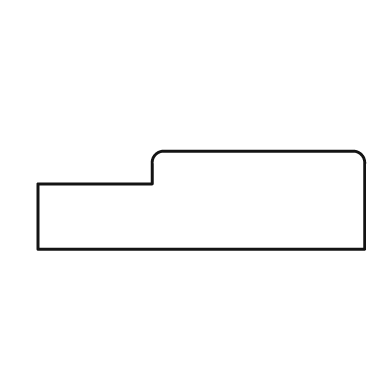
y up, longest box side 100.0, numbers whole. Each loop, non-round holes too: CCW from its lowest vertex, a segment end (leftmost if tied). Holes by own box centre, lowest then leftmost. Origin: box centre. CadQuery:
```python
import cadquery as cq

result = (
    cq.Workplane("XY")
    .moveTo(-50.0, -15.0)
    .lineTo(50.0, -15.0)
    .lineTo(50.0, 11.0)
    .threePointArc((49.0, 14.0), (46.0, 15.0))
    .lineTo(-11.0, 15.0)
    .threePointArc((-14.0, 14.0), (-15.0, 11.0))
    .lineTo(-15.0, 5.0)
    .lineTo(-50.0, 5.0)
    .close()
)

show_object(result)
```